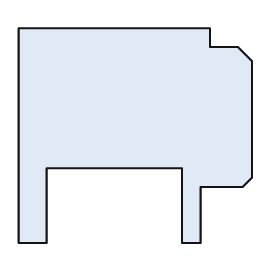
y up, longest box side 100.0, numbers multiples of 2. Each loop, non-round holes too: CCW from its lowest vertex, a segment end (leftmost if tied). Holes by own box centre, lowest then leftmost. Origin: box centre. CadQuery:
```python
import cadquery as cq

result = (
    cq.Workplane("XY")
    .moveTo(-50.0, -46.0)
    .lineTo(-38.0, -46.0)
    .lineTo(-38.0, -14.0)
    .lineTo(20.0, -14.0)
    .lineTo(20.0, -46.0)
    .lineTo(28.0, -46.0)
    .lineTo(28.0, -22.0)
    .lineTo(46.0, -22.0)
    .lineTo(50.0, -18.0)
    .lineTo(50.0, 32.0)
    .lineTo(44.0, 38.0)
    .lineTo(32.0, 38.0)
    .lineTo(32.0, 46.0)
    .lineTo(-50.0, 46.0)
    .close()
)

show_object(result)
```